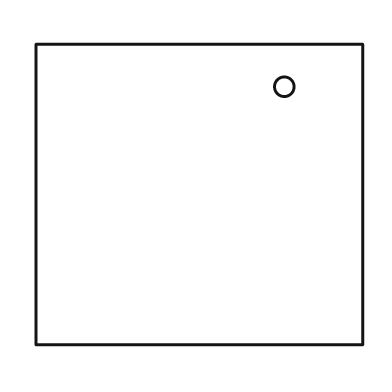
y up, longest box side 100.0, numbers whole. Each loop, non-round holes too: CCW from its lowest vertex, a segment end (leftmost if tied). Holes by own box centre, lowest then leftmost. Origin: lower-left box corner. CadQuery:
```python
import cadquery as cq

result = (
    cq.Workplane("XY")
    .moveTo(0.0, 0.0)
    .lineTo(100.0, 0.0)
    .lineTo(100.0, 92.0)
    .lineTo(0.0, 92.0)
    .close()
    .moveTo(76.0, 79.0)
    .circle(3.0)
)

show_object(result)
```